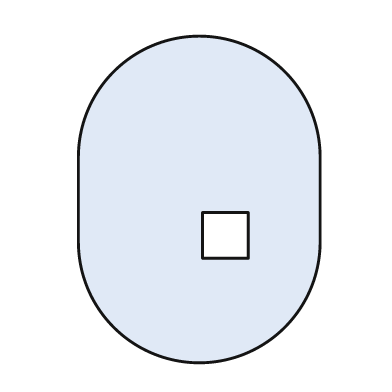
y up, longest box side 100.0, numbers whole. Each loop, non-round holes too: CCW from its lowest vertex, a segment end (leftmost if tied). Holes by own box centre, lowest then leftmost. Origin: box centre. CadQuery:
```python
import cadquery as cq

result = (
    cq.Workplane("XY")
    .moveTo(-37.0, -13.0)
    .threePointArc((0.0, -50.0), (37.0, -13.0))
    .lineTo(37.0, 13.0)
    .threePointArc((0.0, 50.0), (-37.0, 13.0))
    .close()
    .moveTo(1.0, -18.0)
    .lineTo(15.0, -18.0)
    .lineTo(15.0, -4.0)
    .lineTo(1.0, -4.0)
    .close()
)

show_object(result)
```